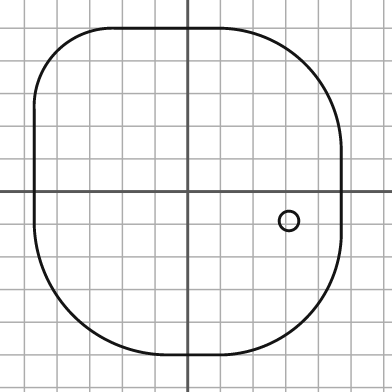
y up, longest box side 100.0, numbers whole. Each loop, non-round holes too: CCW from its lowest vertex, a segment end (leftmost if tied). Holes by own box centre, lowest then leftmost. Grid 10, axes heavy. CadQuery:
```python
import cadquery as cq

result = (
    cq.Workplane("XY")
    .moveTo(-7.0, -50.0)
    .lineTo(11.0, -50.0)
    .threePointArc((36.0, -39.0), (47.0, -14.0))
    .lineTo(47.0, 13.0)
    .threePointArc((36.0, 39.0), (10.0, 50.0))
    .lineTo(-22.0, 50.0)
    .threePointArc((-40.0, 43.0), (-47.0, 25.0))
    .lineTo(-47.0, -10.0)
    .threePointArc((-35.0, -38.0), (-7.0, -50.0))
    .close()
    .moveTo(31.0, -9.0)
    .circle(3.0)
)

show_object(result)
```